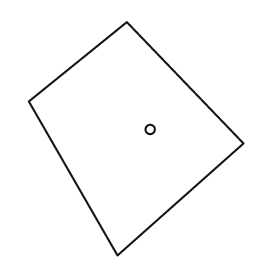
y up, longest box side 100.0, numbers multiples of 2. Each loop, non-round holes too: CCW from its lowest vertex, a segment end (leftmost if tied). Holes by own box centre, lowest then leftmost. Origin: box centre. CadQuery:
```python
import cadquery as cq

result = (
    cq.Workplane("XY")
    .moveTo(-8.0, -50.0)
    .lineTo(46.0, -2.0)
    .lineTo(-4.0, 50.0)
    .lineTo(-46.0, 16.0)
    .close()
    .moveTo(6.0, 4.0)
    .circle(2.0)
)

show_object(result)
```